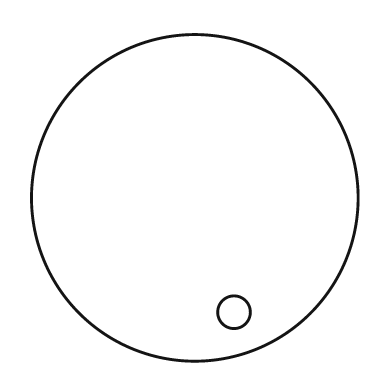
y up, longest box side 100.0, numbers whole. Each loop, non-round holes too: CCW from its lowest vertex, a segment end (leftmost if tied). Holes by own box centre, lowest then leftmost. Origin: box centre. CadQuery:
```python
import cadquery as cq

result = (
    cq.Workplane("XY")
    .moveTo(0.0, 0.0)
    .circle(50.0)
    .moveTo(12.0, -35.0)
    .circle(5.0)
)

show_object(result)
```